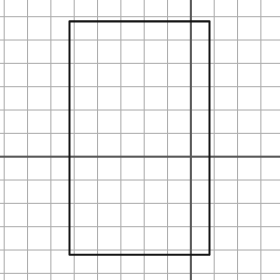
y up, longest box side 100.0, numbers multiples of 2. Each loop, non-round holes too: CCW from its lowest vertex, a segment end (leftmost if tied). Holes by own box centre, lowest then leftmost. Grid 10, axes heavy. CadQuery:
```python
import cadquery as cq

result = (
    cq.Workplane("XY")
    .moveTo(-52.0, -42.0)
    .lineTo(8.0, -42.0)
    .lineTo(8.0, 58.0)
    .lineTo(-52.0, 58.0)
    .close()
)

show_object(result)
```